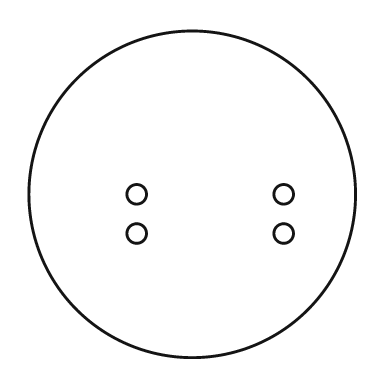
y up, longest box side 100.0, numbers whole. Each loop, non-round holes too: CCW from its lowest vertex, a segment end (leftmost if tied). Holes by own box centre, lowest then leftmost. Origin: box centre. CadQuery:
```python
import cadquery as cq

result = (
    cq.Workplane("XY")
    .moveTo(0.0, 0.0)
    .circle(50.0)
    .moveTo(-17.0, -12.0)
    .circle(3.0)
    .moveTo(28.0, -12.0)
    .circle(3.0)
    .moveTo(-17.0, 0.0)
    .circle(3.0)
    .moveTo(28.0, 0.0)
    .circle(3.0)
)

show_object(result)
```